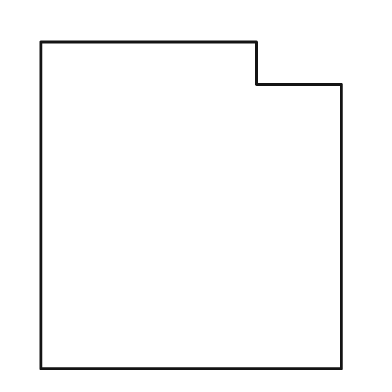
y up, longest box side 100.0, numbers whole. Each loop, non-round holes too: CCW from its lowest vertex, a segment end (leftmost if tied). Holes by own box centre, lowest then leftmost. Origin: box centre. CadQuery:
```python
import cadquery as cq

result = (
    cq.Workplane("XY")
    .moveTo(-46.0, -50.0)
    .lineTo(46.0, -50.0)
    .lineTo(46.0, 37.0)
    .lineTo(20.0, 37.0)
    .lineTo(20.0, 50.0)
    .lineTo(-46.0, 50.0)
    .close()
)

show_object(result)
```